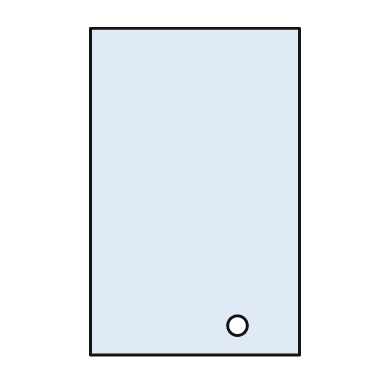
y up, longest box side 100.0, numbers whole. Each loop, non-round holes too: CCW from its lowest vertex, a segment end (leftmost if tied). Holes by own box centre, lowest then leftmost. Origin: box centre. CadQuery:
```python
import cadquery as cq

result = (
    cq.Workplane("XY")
    .moveTo(-32.0, -50.0)
    .lineTo(32.0, -50.0)
    .lineTo(32.0, 50.0)
    .lineTo(-32.0, 50.0)
    .close()
    .moveTo(13.0, -41.0)
    .circle(3.0)
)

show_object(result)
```